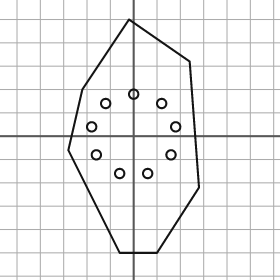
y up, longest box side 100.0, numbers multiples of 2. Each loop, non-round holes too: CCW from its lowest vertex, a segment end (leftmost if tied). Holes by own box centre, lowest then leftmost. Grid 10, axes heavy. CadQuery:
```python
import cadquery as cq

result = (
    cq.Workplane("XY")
    .moveTo(-6.0, -50.0)
    .lineTo(10.0, -50.0)
    .lineTo(28.0, -22.0)
    .lineTo(24.0, 32.0)
    .lineTo(-2.0, 50.0)
    .lineTo(-22.0, 20.0)
    .lineTo(-28.0, -6.0)
    .close()
    .moveTo(-6.0, -16.0)
    .circle(2.0)
    .moveTo(6.0, -16.0)
    .circle(2.0)
    .moveTo(-16.0, -8.0)
    .circle(2.0)
    .moveTo(16.0, -8.0)
    .circle(2.0)
    .moveTo(-18.0, 4.0)
    .circle(2.0)
    .moveTo(18.0, 4.0)
    .circle(2.0)
    .moveTo(-12.0, 14.0)
    .circle(2.0)
    .moveTo(12.0, 14.0)
    .circle(2.0)
    .moveTo(0.0, 18.0)
    .circle(2.0)
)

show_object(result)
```